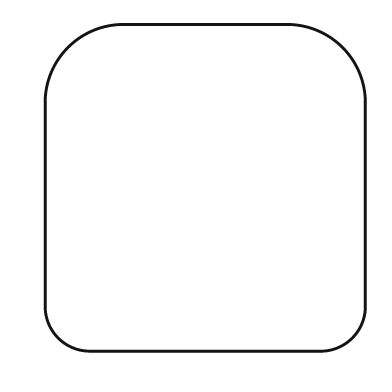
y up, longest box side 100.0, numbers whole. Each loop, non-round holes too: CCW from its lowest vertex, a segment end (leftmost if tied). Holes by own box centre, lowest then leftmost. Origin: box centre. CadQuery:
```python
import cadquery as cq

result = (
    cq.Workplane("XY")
    .moveTo(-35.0, -50.0)
    .lineTo(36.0, -50.0)
    .threePointArc((45.0, -46.0), (49.0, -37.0))
    .lineTo(49.0, 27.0)
    .threePointArc((42.0, 43.0), (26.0, 50.0))
    .lineTo(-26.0, 50.0)
    .threePointArc((-42.0, 43.0), (-49.0, 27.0))
    .lineTo(-49.0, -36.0)
    .threePointArc((-45.0, -46.0), (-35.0, -50.0))
    .close()
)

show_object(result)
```